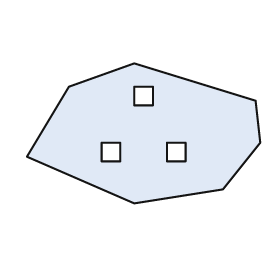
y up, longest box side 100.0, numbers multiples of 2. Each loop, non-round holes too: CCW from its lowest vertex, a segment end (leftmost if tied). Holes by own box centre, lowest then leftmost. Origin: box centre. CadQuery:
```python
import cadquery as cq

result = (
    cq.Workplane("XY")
    .moveTo(-4.0, -30.0)
    .lineTo(34.0, -24.0)
    .lineTo(50.0, -4.0)
    .lineTo(48.0, 14.0)
    .lineTo(-4.0, 30.0)
    .lineTo(-32.0, 20.0)
    .lineTo(-50.0, -10.0)
    .close()
    .moveTo(-18.0, -12.0)
    .lineTo(-10.0, -12.0)
    .lineTo(-10.0, -4.0)
    .lineTo(-18.0, -4.0)
    .close()
    .moveTo(10.0, -12.0)
    .lineTo(18.0, -12.0)
    .lineTo(18.0, -4.0)
    .lineTo(10.0, -4.0)
    .close()
    .moveTo(-4.0, 12.0)
    .lineTo(4.0, 12.0)
    .lineTo(4.0, 20.0)
    .lineTo(-4.0, 20.0)
    .close()
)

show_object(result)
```